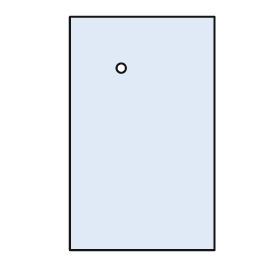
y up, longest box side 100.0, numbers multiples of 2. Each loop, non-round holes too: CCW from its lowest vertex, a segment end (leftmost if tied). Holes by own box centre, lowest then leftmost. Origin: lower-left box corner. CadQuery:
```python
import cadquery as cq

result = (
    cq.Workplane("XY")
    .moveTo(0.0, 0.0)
    .lineTo(62.0, 0.0)
    .lineTo(62.0, 100.0)
    .lineTo(0.0, 100.0)
    .close()
    .moveTo(22.0, 78.0)
    .circle(2.0)
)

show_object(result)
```